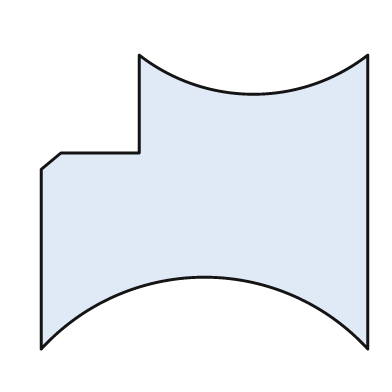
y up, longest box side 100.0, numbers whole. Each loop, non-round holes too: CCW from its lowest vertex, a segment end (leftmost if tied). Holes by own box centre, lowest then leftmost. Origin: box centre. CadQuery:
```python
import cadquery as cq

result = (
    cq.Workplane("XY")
    .moveTo(-50.0, -45.0)
    .threePointArc((0.0, -23.0), (50.0, -45.0))
    .lineTo(50.0, 45.0)
    .threePointArc((15.0, 33.0), (-20.0, 45.0))
    .lineTo(-20.0, 15.0)
    .lineTo(-44.0, 15.0)
    .lineTo(-50.0, 10.0)
    .close()
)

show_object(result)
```